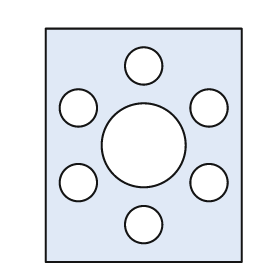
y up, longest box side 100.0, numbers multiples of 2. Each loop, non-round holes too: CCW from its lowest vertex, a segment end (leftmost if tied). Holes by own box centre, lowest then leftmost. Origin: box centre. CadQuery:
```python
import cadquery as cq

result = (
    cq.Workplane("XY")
    .moveTo(-42.0, -50.0)
    .lineTo(42.0, -50.0)
    .lineTo(42.0, 50.0)
    .lineTo(-42.0, 50.0)
    .close()
    .moveTo(0.0, -34.0)
    .circle(8.0)
    .moveTo(-28.0, -16.0)
    .circle(8.0)
    .moveTo(28.0, -16.0)
    .circle(8.0)
    .moveTo(0.0, 0.0)
    .circle(18.0)
    .moveTo(-28.0, 16.0)
    .circle(8.0)
    .moveTo(28.0, 16.0)
    .circle(8.0)
    .moveTo(0.0, 34.0)
    .circle(8.0)
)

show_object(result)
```